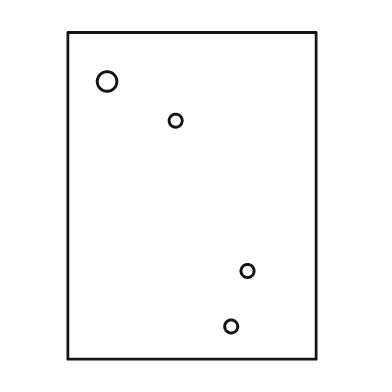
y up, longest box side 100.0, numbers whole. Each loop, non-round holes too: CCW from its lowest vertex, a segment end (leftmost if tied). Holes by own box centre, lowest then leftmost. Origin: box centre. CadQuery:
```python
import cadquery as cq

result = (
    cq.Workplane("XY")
    .moveTo(-38.0, -50.0)
    .lineTo(38.0, -50.0)
    .lineTo(38.0, 50.0)
    .lineTo(-38.0, 50.0)
    .close()
    .moveTo(12.0, -40.0)
    .circle(2.0)
    .moveTo(17.0, -23.0)
    .circle(2.0)
    .moveTo(-5.0, 23.0)
    .circle(2.0)
    .moveTo(-26.0, 35.0)
    .circle(3.0)
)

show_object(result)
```